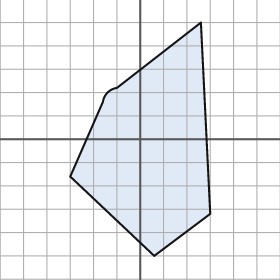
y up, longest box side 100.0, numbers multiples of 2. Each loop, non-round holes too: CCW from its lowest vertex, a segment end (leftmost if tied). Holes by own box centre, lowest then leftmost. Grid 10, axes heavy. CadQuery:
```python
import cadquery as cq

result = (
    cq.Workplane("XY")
    .moveTo(6.0, -50.0)
    .lineTo(30.0, -32.0)
    .lineTo(26.0, 50.0)
    .lineTo(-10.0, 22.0)
    .threePointArc((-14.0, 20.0), (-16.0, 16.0))
    .lineTo(-30.0, -16.0)
    .close()
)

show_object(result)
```